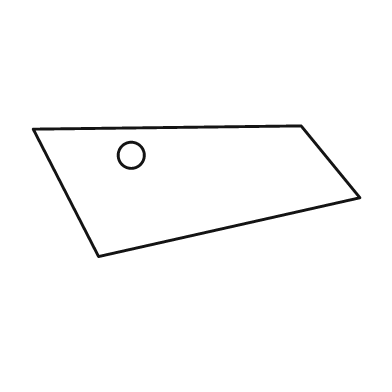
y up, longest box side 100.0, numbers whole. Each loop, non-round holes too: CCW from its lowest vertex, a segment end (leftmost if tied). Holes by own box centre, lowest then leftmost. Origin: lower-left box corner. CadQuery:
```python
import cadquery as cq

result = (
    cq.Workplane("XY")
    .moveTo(20.0, 0.0)
    .lineTo(100.0, 18.0)
    .lineTo(82.0, 40.0)
    .lineTo(0.0, 39.0)
    .close()
    .moveTo(30.0, 31.0)
    .circle(4.0)
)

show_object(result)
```